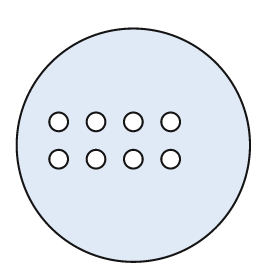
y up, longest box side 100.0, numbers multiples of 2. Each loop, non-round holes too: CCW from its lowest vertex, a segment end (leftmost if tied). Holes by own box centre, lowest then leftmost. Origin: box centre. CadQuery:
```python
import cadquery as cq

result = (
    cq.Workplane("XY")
    .moveTo(0.0, 0.0)
    .circle(50.0)
    .moveTo(-32.0, -6.0)
    .circle(4.0)
    .moveTo(-16.0, -6.0)
    .circle(4.0)
    .moveTo(0.0, -6.0)
    .circle(4.0)
    .moveTo(16.0, -6.0)
    .circle(4.0)
    .moveTo(-32.0, 10.0)
    .circle(4.0)
    .moveTo(-16.0, 10.0)
    .circle(4.0)
    .moveTo(0.0, 10.0)
    .circle(4.0)
    .moveTo(16.0, 10.0)
    .circle(4.0)
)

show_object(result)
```